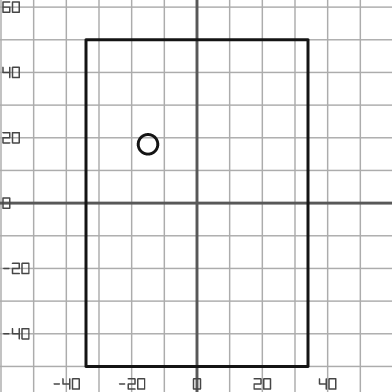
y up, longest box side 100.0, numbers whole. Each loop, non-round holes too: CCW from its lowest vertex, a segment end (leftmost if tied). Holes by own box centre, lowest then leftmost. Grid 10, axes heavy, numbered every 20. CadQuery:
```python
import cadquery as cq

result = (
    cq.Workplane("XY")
    .moveTo(-34.0, -50.0)
    .lineTo(34.0, -50.0)
    .lineTo(34.0, 50.0)
    .lineTo(-34.0, 50.0)
    .close()
    .moveTo(-15.0, 18.0)
    .circle(3.0)
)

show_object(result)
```